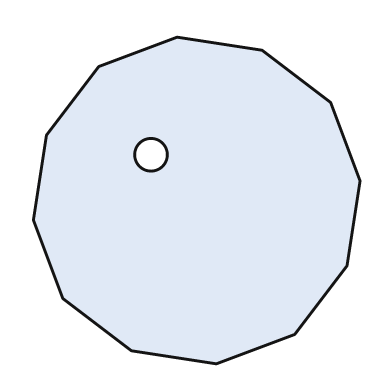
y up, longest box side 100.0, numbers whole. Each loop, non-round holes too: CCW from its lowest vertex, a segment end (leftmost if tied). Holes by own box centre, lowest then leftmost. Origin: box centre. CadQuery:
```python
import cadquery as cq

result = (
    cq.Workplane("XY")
    .moveTo(6.0, -50.0)
    .lineTo(30.0, -41.0)
    .lineTo(46.0, -20.0)
    .lineTo(50.0, 6.0)
    .lineTo(41.0, 30.0)
    .lineTo(20.0, 46.0)
    .lineTo(-6.0, 50.0)
    .lineTo(-30.0, 41.0)
    .lineTo(-46.0, 20.0)
    .lineTo(-50.0, -6.0)
    .lineTo(-41.0, -30.0)
    .lineTo(-20.0, -46.0)
    .close()
    .moveTo(-14.0, 14.0)
    .circle(5.0)
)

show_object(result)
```